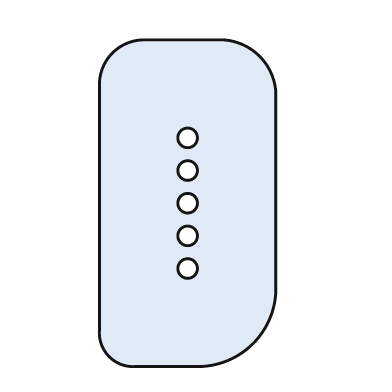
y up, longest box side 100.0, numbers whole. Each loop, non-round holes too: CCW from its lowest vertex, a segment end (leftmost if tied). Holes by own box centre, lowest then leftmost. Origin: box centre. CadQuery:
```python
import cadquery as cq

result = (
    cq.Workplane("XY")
    .moveTo(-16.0, -50.0)
    .lineTo(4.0, -50.0)
    .threePointArc((20.0, -43.0), (27.0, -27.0))
    .lineTo(27.0, 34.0)
    .threePointArc((22.0, 45.0), (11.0, 50.0))
    .lineTo(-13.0, 50.0)
    .threePointArc((-23.0, 46.0), (-27.0, 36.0))
    .lineTo(-27.0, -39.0)
    .threePointArc((-24.0, -47.0), (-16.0, -50.0))
    .close()
    .moveTo(0.0, -20.0)
    .circle(3.0)
    .moveTo(0.0, -10.0)
    .circle(3.0)
    .moveTo(0.0, 0.0)
    .circle(3.0)
    .moveTo(0.0, 10.0)
    .circle(3.0)
    .moveTo(0.0, 20.0)
    .circle(3.0)
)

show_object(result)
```